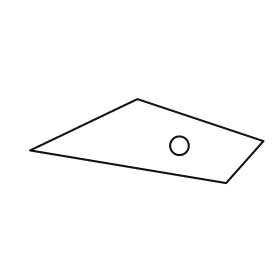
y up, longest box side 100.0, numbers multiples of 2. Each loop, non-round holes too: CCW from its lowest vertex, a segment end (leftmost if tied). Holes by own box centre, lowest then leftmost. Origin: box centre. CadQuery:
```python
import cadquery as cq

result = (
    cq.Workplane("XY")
    .moveTo(34.0, -18.0)
    .lineTo(50.0, 0.0)
    .lineTo(-4.0, 18.0)
    .lineTo(-50.0, -4.0)
    .close()
    .moveTo(14.0, -2.0)
    .circle(4.0)
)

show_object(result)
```